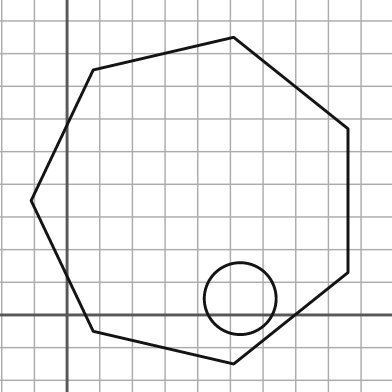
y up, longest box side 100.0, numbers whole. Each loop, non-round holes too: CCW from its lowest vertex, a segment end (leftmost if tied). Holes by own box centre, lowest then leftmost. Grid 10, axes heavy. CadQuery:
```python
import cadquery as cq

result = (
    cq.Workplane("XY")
    .moveTo(51.0, -15.0)
    .lineTo(86.0, 13.0)
    .lineTo(86.0, 57.0)
    .lineTo(51.0, 85.0)
    .lineTo(8.0, 75.0)
    .lineTo(-11.0, 35.0)
    .lineTo(8.0, -5.0)
    .close()
    .moveTo(53.0, 5.0)
    .circle(11.0)
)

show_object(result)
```